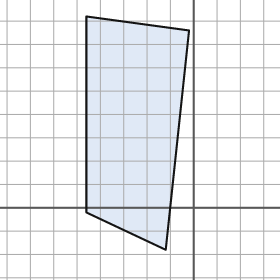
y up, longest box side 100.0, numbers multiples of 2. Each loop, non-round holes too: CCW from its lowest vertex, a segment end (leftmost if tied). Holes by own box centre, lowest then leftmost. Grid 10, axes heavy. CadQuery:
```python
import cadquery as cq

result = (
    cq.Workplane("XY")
    .moveTo(-12.0, -18.0)
    .lineTo(-2.0, 76.0)
    .lineTo(-46.0, 82.0)
    .lineTo(-46.0, -2.0)
    .close()
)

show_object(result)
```